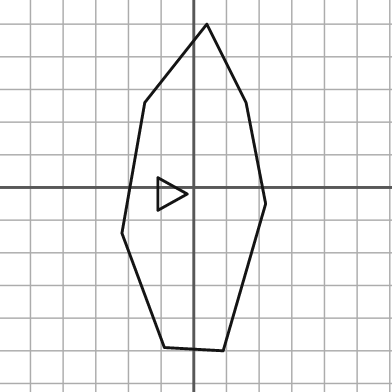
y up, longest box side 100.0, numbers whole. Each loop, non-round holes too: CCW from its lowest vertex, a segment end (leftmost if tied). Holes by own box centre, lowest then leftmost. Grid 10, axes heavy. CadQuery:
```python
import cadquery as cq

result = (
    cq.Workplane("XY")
    .moveTo(9.0, -50.0)
    .lineTo(22.0, -5.0)
    .lineTo(16.0, 26.0)
    .lineTo(4.0, 50.0)
    .lineTo(-15.0, 26.0)
    .lineTo(-22.0, -14.0)
    .lineTo(-9.0, -49.0)
    .close()
    .moveTo(-11.0, -7.0)
    .lineTo(-2.0, -2.0)
    .lineTo(-11.0, 3.0)
    .close()
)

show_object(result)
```